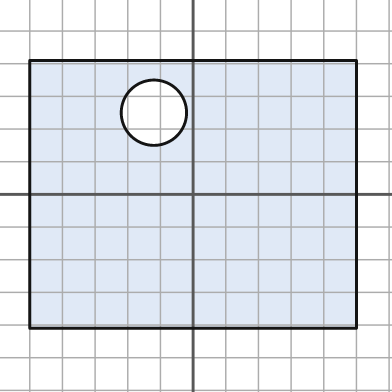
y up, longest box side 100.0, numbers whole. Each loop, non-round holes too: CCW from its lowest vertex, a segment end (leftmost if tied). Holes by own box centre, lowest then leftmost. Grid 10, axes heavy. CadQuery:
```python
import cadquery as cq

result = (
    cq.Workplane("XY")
    .moveTo(-50.0, -41.0)
    .lineTo(50.0, -41.0)
    .lineTo(50.0, 41.0)
    .lineTo(-50.0, 41.0)
    .close()
    .moveTo(-12.0, 25.0)
    .circle(10.0)
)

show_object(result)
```